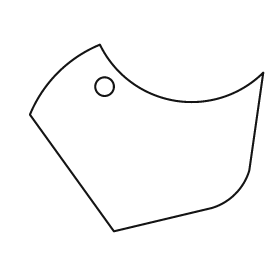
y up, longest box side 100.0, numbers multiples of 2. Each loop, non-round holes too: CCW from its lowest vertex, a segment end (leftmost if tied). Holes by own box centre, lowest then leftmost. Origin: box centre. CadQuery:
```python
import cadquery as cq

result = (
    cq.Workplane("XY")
    .moveTo(-14.0, -40.0)
    .lineTo(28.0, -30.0)
    .threePointArc((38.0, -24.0), (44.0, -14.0))
    .lineTo(50.0, 28.0)
    .threePointArc((12.0, 16.0), (-20.0, 40.0))
    .threePointArc((-38.0, 28.0), (-50.0, 10.0))
    .close()
    .moveTo(-18.0, 22.0)
    .circle(4.0)
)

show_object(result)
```